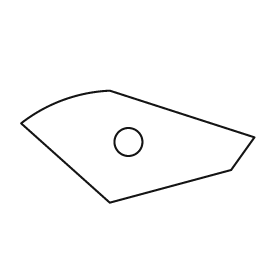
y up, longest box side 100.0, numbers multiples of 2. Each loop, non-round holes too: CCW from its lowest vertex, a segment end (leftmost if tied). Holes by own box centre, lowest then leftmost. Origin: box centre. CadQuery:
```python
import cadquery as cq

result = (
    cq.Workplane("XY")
    .moveTo(-12.0, -24.0)
    .lineTo(40.0, -10.0)
    .lineTo(50.0, 4.0)
    .lineTo(-12.0, 24.0)
    .threePointArc((-32.0, 20.0), (-50.0, 10.0))
    .close()
    .moveTo(-4.0, 2.0)
    .circle(6.0)
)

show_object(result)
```